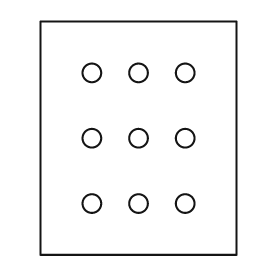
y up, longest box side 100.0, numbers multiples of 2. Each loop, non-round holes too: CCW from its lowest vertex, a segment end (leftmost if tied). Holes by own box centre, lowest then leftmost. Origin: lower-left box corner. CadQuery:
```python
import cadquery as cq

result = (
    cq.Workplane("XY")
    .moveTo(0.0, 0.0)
    .lineTo(84.0, 0.0)
    .lineTo(84.0, 100.0)
    .lineTo(0.0, 100.0)
    .close()
    .moveTo(22.0, 22.0)
    .circle(4.0)
    .moveTo(42.0, 22.0)
    .circle(4.0)
    .moveTo(62.0, 22.0)
    .circle(4.0)
    .moveTo(22.0, 50.0)
    .circle(4.0)
    .moveTo(42.0, 50.0)
    .circle(4.0)
    .moveTo(62.0, 50.0)
    .circle(4.0)
    .moveTo(22.0, 78.0)
    .circle(4.0)
    .moveTo(42.0, 78.0)
    .circle(4.0)
    .moveTo(62.0, 78.0)
    .circle(4.0)
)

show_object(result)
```